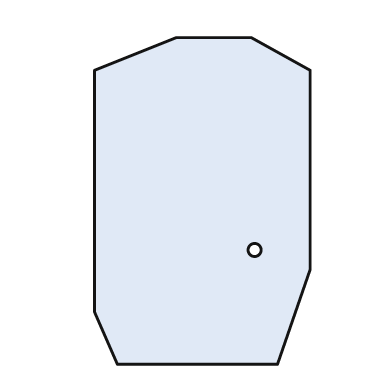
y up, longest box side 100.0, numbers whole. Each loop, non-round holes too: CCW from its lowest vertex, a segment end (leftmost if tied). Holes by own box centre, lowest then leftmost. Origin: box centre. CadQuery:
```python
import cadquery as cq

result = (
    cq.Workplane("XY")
    .moveTo(-26.0, -50.0)
    .lineTo(23.0, -50.0)
    .lineTo(33.0, -21.0)
    .lineTo(33.0, 40.0)
    .lineTo(15.0, 50.0)
    .lineTo(-8.0, 50.0)
    .lineTo(-33.0, 40.0)
    .lineTo(-33.0, -34.0)
    .close()
    .moveTo(16.0, -15.0)
    .circle(2.0)
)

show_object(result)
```